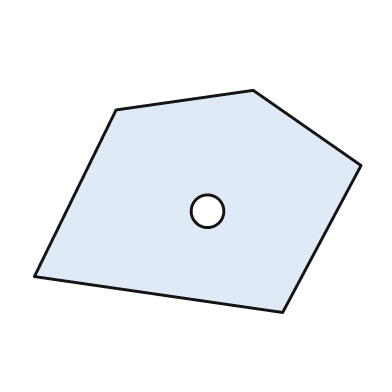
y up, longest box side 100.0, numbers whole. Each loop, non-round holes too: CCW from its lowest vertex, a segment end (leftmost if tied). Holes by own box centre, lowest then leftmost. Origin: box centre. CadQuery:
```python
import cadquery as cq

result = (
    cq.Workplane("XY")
    .moveTo(26.0, -34.0)
    .lineTo(50.0, 11.0)
    .lineTo(17.0, 34.0)
    .lineTo(-25.0, 28.0)
    .lineTo(-50.0, -23.0)
    .close()
    .moveTo(3.0, -3.0)
    .circle(5.0)
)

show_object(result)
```